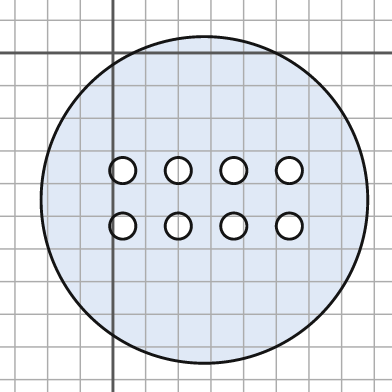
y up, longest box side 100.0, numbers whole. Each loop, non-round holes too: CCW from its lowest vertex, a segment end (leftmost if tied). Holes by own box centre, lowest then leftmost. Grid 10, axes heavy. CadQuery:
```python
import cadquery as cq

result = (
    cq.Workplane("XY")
    .moveTo(28.0, -45.0)
    .circle(50.0)
    .moveTo(3.0, -53.0)
    .circle(4.0)
    .moveTo(20.0, -53.0)
    .circle(4.0)
    .moveTo(37.0, -53.0)
    .circle(4.0)
    .moveTo(54.0, -53.0)
    .circle(4.0)
    .moveTo(3.0, -36.0)
    .circle(4.0)
    .moveTo(20.0, -36.0)
    .circle(4.0)
    .moveTo(37.0, -36.0)
    .circle(4.0)
    .moveTo(54.0, -36.0)
    .circle(4.0)
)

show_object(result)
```